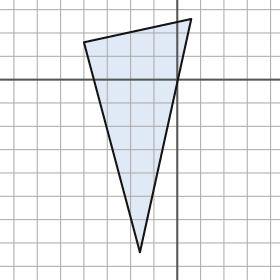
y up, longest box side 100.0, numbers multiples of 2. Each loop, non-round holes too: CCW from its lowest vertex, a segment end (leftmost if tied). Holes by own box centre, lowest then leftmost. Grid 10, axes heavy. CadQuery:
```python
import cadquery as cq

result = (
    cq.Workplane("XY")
    .moveTo(-16.0, -74.0)
    .lineTo(6.0, 26.0)
    .lineTo(-40.0, 16.0)
    .close()
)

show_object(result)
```